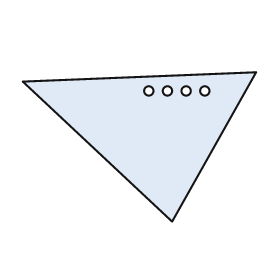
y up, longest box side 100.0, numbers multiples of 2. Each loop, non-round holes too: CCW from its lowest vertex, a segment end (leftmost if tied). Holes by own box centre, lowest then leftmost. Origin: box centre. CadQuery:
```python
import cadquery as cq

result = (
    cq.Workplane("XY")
    .moveTo(14.0, -32.0)
    .lineTo(50.0, 32.0)
    .lineTo(-50.0, 28.0)
    .close()
    .moveTo(4.0, 24.0)
    .circle(2.0)
    .moveTo(12.0, 24.0)
    .circle(2.0)
    .moveTo(20.0, 24.0)
    .circle(2.0)
    .moveTo(28.0, 24.0)
    .circle(2.0)
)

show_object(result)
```